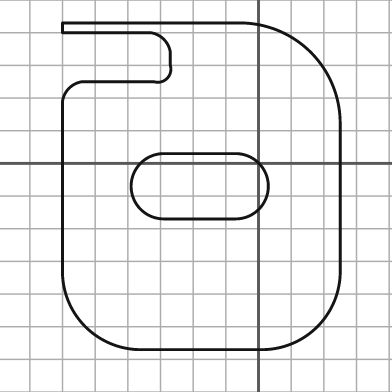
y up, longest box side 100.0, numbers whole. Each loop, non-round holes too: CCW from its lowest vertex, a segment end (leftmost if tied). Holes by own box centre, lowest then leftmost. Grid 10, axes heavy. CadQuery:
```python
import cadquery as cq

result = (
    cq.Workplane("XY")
    .moveTo(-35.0, -57.0)
    .lineTo(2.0, -57.0)
    .threePointArc((18.0, -50.0), (25.0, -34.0))
    .lineTo(25.0, 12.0)
    .threePointArc((16.0, 34.0), (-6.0, 43.0))
    .lineTo(-60.0, 43.0)
    .lineTo(-60.0, 40.0)
    .lineTo(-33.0, 40.0)
    .threePointArc((-29.0, 38.0), (-27.0, 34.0))
    .lineTo(-27.0, 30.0)
    .threePointArc((-28.0, 26.0), (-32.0, 25.0))
    .lineTo(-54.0, 25.0)
    .threePointArc((-58.0, 23.0), (-60.0, 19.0))
    .lineTo(-60.0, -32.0)
    .threePointArc((-53.0, -50.0), (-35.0, -57.0))
    .close()
    .moveTo(-29.0, -17.0)
    .lineTo(-7.0, -17.0)
    .threePointArc((3.0, -7.0), (-7.0, 3.0))
    .lineTo(-29.0, 3.0)
    .threePointArc((-39.0, -7.0), (-29.0, -17.0))
    .close()
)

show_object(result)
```